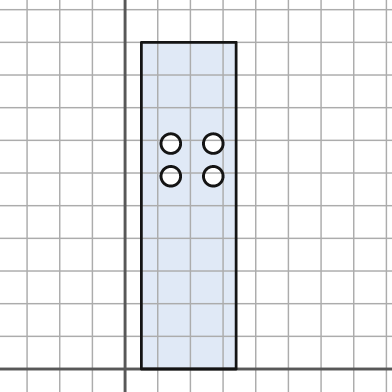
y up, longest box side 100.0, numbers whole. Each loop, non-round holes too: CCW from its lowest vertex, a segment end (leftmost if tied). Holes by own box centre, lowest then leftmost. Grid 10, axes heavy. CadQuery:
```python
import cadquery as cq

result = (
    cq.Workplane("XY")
    .moveTo(5.0, 0.0)
    .lineTo(34.0, 0.0)
    .lineTo(34.0, 100.0)
    .lineTo(5.0, 100.0)
    .close()
    .moveTo(14.0, 59.0)
    .circle(3.0)
    .moveTo(27.0, 59.0)
    .circle(3.0)
    .moveTo(14.0, 69.0)
    .circle(3.0)
    .moveTo(27.0, 69.0)
    .circle(3.0)
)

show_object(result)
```